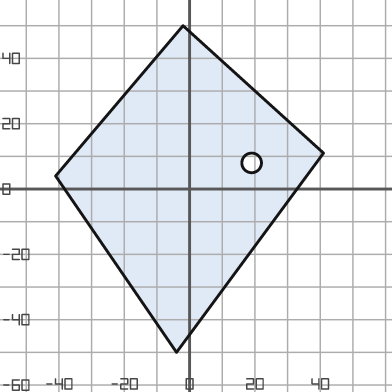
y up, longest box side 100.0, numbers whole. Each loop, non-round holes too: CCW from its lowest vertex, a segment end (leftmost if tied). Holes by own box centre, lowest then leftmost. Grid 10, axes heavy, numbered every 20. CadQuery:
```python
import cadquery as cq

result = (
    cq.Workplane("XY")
    .moveTo(-4.0, -50.0)
    .lineTo(41.0, 11.0)
    .lineTo(-2.0, 50.0)
    .lineTo(-41.0, 4.0)
    .close()
    .moveTo(19.0, 8.0)
    .circle(3.0)
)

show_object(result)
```